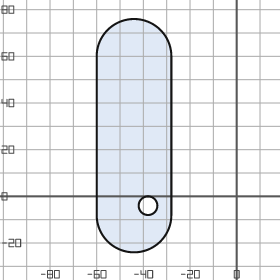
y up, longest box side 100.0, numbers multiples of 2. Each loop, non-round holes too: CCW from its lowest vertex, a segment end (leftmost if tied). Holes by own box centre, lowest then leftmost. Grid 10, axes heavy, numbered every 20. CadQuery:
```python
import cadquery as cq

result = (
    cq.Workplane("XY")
    .moveTo(-60.0, -8.0)
    .threePointArc((-44.0, -24.0), (-28.0, -8.0))
    .lineTo(-28.0, 60.0)
    .threePointArc((-44.0, 76.0), (-60.0, 60.0))
    .close()
    .moveTo(-38.0, -4.0)
    .circle(4.0)
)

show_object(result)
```